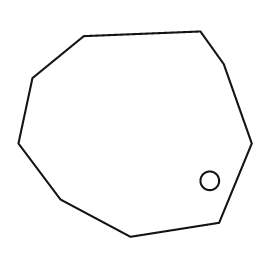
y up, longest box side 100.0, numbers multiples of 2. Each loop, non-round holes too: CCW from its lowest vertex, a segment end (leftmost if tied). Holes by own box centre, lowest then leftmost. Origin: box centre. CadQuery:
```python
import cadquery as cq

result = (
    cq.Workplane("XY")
    .moveTo(-2.0, -44.0)
    .lineTo(36.0, -38.0)
    .lineTo(50.0, -4.0)
    .lineTo(38.0, 30.0)
    .lineTo(28.0, 44.0)
    .lineTo(-22.0, 42.0)
    .lineTo(-44.0, 24.0)
    .lineTo(-50.0, -4.0)
    .lineTo(-32.0, -28.0)
    .close()
    .moveTo(32.0, -20.0)
    .circle(4.0)
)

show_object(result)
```